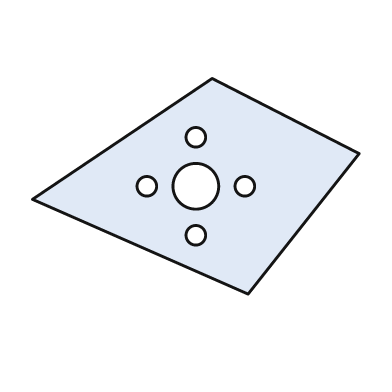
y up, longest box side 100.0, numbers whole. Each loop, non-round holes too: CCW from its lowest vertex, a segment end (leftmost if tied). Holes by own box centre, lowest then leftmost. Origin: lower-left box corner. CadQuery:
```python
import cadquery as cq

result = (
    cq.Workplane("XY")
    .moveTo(66.0, 0.0)
    .lineTo(100.0, 43.0)
    .lineTo(55.0, 66.0)
    .lineTo(0.0, 29.0)
    .close()
    .moveTo(50.0, 18.0)
    .circle(3.0)
    .moveTo(35.0, 33.0)
    .circle(3.0)
    .moveTo(50.0, 33.0)
    .circle(7.0)
    .moveTo(65.0, 33.0)
    .circle(3.0)
    .moveTo(50.0, 48.0)
    .circle(3.0)
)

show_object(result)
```